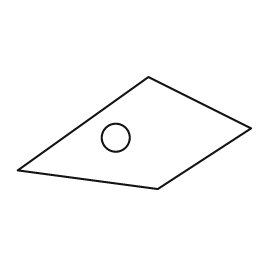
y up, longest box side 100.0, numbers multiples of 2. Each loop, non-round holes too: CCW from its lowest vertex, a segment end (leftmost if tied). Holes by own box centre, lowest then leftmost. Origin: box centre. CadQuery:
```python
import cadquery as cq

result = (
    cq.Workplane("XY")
    .moveTo(10.0, -24.0)
    .lineTo(50.0, 2.0)
    .lineTo(6.0, 24.0)
    .lineTo(-50.0, -16.0)
    .close()
    .moveTo(-8.0, -2.0)
    .circle(6.0)
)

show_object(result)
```